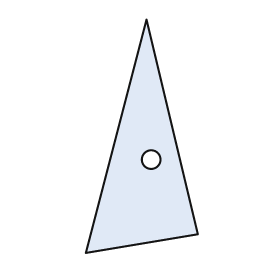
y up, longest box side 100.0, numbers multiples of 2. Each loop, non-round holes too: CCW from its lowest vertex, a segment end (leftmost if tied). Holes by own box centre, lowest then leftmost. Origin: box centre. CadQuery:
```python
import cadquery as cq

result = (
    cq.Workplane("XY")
    .moveTo(-24.0, -50.0)
    .lineTo(24.0, -42.0)
    .lineTo(2.0, 50.0)
    .close()
    .moveTo(4.0, -10.0)
    .circle(4.0)
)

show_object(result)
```